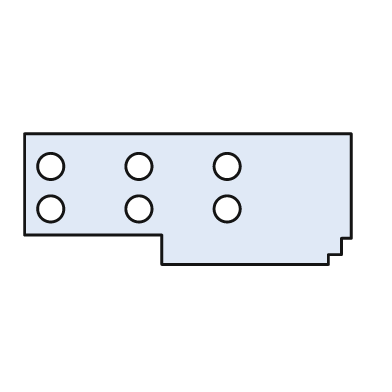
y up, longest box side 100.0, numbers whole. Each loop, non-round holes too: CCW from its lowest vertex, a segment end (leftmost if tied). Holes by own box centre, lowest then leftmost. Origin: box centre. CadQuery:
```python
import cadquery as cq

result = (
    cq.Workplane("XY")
    .moveTo(-8.0, -20.0)
    .lineTo(43.0, -20.0)
    .lineTo(43.0, -17.0)
    .lineTo(47.0, -17.0)
    .lineTo(47.0, -12.0)
    .lineTo(50.0, -12.0)
    .lineTo(50.0, 20.0)
    .lineTo(-50.0, 20.0)
    .lineTo(-50.0, -11.0)
    .lineTo(-8.0, -11.0)
    .close()
    .moveTo(-42.0, -3.0)
    .circle(4.0)
    .moveTo(-15.0, -3.0)
    .circle(4.0)
    .moveTo(12.0, -3.0)
    .circle(4.0)
    .moveTo(-42.0, 10.0)
    .circle(4.0)
    .moveTo(-15.0, 10.0)
    .circle(4.0)
    .moveTo(12.0, 10.0)
    .circle(4.0)
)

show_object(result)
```